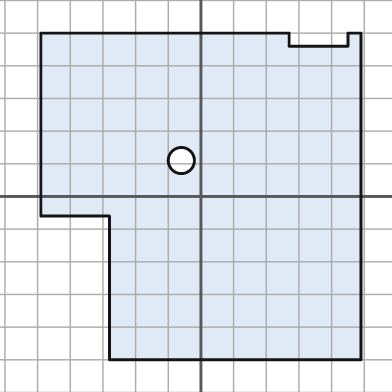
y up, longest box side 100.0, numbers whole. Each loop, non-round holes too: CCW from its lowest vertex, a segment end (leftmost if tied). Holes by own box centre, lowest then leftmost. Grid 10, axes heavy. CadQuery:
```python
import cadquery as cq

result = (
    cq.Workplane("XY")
    .moveTo(-28.0, -50.0)
    .lineTo(49.0, -50.0)
    .lineTo(49.0, 50.0)
    .lineTo(45.0, 50.0)
    .lineTo(45.0, 46.0)
    .lineTo(27.0, 46.0)
    .lineTo(27.0, 50.0)
    .lineTo(-49.0, 50.0)
    .lineTo(-49.0, -6.0)
    .lineTo(-28.0, -6.0)
    .close()
    .moveTo(-6.0, 11.0)
    .circle(4.0)
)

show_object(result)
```